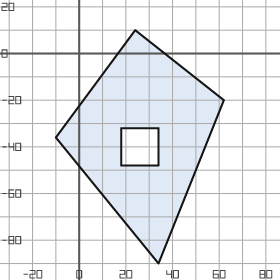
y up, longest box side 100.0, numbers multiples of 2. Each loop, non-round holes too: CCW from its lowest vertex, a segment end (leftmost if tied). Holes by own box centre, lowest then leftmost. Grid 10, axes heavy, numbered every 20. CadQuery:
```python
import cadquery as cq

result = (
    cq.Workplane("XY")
    .moveTo(34.0, -90.0)
    .lineTo(62.0, -20.0)
    .lineTo(24.0, 10.0)
    .lineTo(-10.0, -36.0)
    .close()
    .moveTo(18.0, -48.0)
    .lineTo(34.0, -48.0)
    .lineTo(34.0, -32.0)
    .lineTo(18.0, -32.0)
    .close()
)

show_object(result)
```